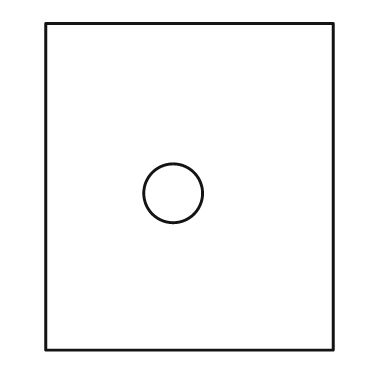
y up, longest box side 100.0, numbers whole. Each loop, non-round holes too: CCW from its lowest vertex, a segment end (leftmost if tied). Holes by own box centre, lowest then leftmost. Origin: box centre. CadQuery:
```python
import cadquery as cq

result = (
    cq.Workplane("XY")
    .moveTo(-44.0, -50.0)
    .lineTo(44.0, -50.0)
    .lineTo(44.0, 50.0)
    .lineTo(-44.0, 50.0)
    .close()
    .moveTo(-5.0, -2.0)
    .circle(9.0)
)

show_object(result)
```